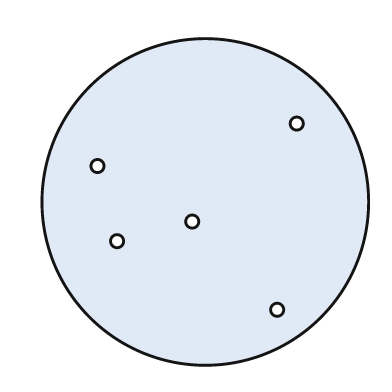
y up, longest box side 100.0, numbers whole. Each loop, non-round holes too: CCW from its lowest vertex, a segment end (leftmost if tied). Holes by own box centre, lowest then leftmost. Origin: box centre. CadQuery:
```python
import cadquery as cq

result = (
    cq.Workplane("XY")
    .moveTo(0.0, 0.0)
    .circle(50.0)
    .moveTo(22.0, -33.0)
    .circle(2.0)
    .moveTo(-27.0, -12.0)
    .circle(2.0)
    .moveTo(-4.0, -6.0)
    .circle(2.0)
    .moveTo(-33.0, 11.0)
    .circle(2.0)
    .moveTo(28.0, 24.0)
    .circle(2.0)
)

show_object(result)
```